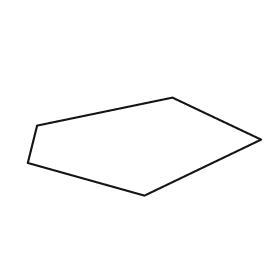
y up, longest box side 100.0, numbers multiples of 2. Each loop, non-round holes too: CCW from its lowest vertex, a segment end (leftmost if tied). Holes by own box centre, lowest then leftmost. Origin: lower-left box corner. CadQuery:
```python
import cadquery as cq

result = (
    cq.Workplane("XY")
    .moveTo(50.0, 0.0)
    .lineTo(100.0, 24.0)
    .lineTo(62.0, 42.0)
    .lineTo(4.0, 30.0)
    .lineTo(0.0, 14.0)
    .close()
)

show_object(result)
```